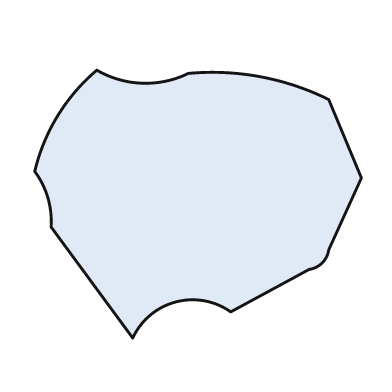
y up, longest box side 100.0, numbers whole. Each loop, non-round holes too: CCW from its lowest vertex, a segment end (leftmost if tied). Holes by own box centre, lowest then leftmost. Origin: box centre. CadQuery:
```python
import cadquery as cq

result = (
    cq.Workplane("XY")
    .moveTo(-20.0, -41.0)
    .threePointArc((-7.0, -30.0), (10.0, -33.0))
    .lineTo(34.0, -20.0)
    .threePointArc((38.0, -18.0), (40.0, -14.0))
    .lineTo(50.0, 8.0)
    .lineTo(40.0, 32.0)
    .threePointArc((19.0, 39.0), (-3.0, 40.0))
    .threePointArc((-17.0, 37.0), (-31.0, 41.0))
    .threePointArc((-43.0, 27.0), (-50.0, 10.0))
    .threePointArc((-46.0, 2.0), (-45.0, -7.0))
    .close()
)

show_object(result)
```